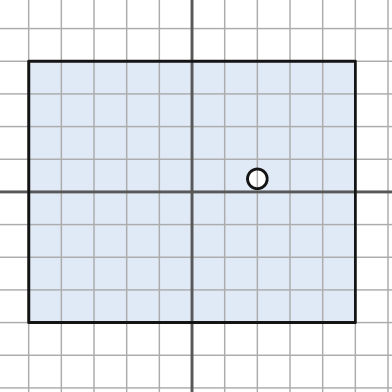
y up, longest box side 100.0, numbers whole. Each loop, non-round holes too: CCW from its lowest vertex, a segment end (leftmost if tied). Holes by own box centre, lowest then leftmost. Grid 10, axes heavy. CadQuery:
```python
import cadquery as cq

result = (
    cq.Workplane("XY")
    .moveTo(-50.0, -40.0)
    .lineTo(50.0, -40.0)
    .lineTo(50.0, 40.0)
    .lineTo(-50.0, 40.0)
    .close()
    .moveTo(20.0, 4.0)
    .circle(3.0)
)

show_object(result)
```